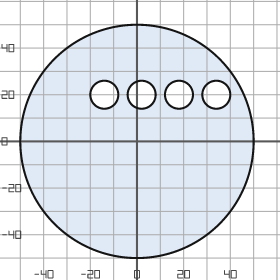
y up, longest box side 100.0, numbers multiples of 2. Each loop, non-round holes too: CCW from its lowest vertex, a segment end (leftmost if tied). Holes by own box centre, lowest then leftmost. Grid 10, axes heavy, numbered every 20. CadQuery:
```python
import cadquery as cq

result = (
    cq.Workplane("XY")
    .moveTo(0.0, 0.0)
    .circle(50.0)
    .moveTo(-14.0, 20.0)
    .circle(6.0)
    .moveTo(2.0, 20.0)
    .circle(6.0)
    .moveTo(18.0, 20.0)
    .circle(6.0)
    .moveTo(34.0, 20.0)
    .circle(6.0)
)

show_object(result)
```